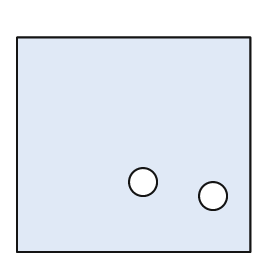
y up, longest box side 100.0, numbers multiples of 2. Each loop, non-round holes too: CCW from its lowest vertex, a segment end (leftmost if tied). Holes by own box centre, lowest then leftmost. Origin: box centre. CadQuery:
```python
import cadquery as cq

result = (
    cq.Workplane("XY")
    .moveTo(-50.0, -46.0)
    .lineTo(50.0, -46.0)
    .lineTo(50.0, 46.0)
    .lineTo(-50.0, 46.0)
    .close()
    .moveTo(34.0, -22.0)
    .circle(6.0)
    .moveTo(4.0, -16.0)
    .circle(6.0)
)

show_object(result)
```